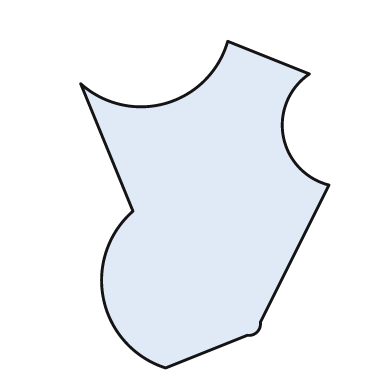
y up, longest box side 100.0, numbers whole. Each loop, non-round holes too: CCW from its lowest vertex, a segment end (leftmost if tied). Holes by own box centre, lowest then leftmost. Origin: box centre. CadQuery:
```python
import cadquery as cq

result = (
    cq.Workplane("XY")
    .moveTo(-12.0, -50.0)
    .lineTo(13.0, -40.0)
    .threePointArc((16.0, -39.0), (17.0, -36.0))
    .lineTo(38.0, 6.0)
    .threePointArc((24.0, 21.0), (32.0, 40.0))
    .lineTo(7.0, 50.0)
    .threePointArc((-12.0, 31.0), (-38.0, 37.0))
    .lineTo(-22.0, -2.0)
    .threePointArc((-31.0, -29.0), (-12.0, -50.0))
    .close()
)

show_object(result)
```